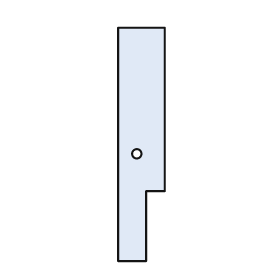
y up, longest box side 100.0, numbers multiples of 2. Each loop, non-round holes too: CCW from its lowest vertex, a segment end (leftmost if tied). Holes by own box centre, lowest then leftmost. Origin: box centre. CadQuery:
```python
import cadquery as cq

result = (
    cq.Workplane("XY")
    .moveTo(-10.0, -50.0)
    .lineTo(2.0, -50.0)
    .lineTo(2.0, -20.0)
    .lineTo(10.0, -20.0)
    .lineTo(10.0, 50.0)
    .lineTo(-10.0, 50.0)
    .close()
    .moveTo(-2.0, -4.0)
    .circle(2.0)
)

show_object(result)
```